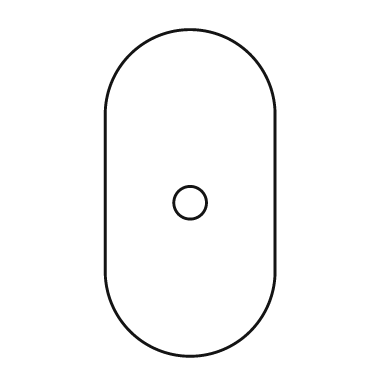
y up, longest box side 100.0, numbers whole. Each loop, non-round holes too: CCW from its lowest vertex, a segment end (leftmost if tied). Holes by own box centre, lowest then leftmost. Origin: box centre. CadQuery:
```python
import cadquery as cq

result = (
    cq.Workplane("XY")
    .moveTo(-26.0, -24.0)
    .threePointArc((0.0, -50.0), (26.0, -24.0))
    .lineTo(26.0, 24.0)
    .threePointArc((0.0, 50.0), (-26.0, 24.0))
    .close()
    .moveTo(0.0, -3.0)
    .circle(5.0)
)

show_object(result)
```